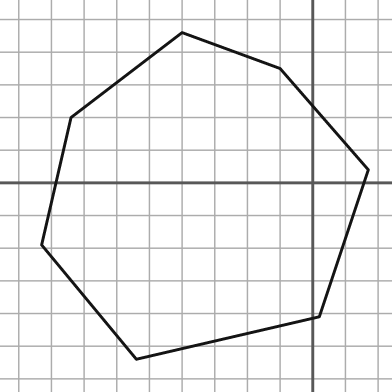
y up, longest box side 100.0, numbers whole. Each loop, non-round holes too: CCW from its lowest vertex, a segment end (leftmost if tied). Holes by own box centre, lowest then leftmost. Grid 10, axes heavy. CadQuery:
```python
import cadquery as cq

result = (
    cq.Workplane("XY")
    .moveTo(-54.0, -54.0)
    .lineTo(2.0, -41.0)
    .lineTo(17.0, 4.0)
    .lineTo(-10.0, 35.0)
    .lineTo(-40.0, 46.0)
    .lineTo(-74.0, 20.0)
    .lineTo(-83.0, -19.0)
    .close()
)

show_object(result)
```